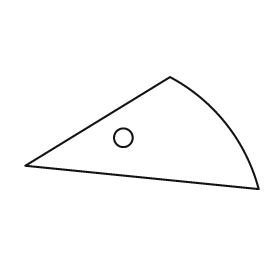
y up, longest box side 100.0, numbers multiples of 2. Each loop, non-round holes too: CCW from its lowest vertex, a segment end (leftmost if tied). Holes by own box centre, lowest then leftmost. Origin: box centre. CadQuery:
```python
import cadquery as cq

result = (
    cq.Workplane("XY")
    .moveTo(50.0, -24.0)
    .threePointArc((36.0, 4.0), (12.0, 24.0))
    .lineTo(-50.0, -14.0)
    .close()
    .moveTo(-8.0, -2.0)
    .circle(4.0)
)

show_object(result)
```